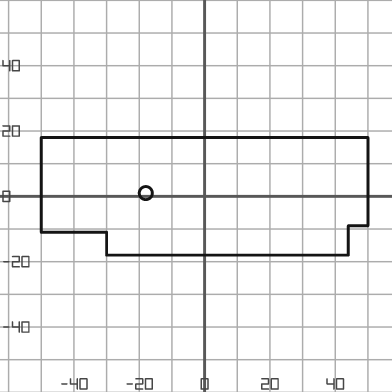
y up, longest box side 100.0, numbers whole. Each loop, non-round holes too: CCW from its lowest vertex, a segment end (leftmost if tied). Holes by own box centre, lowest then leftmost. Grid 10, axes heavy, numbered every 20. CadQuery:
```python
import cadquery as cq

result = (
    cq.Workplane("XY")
    .moveTo(-30.0, -18.0)
    .lineTo(44.0, -18.0)
    .lineTo(44.0, -9.0)
    .lineTo(50.0, -9.0)
    .lineTo(50.0, 18.0)
    .lineTo(-50.0, 18.0)
    .lineTo(-50.0, -11.0)
    .lineTo(-30.0, -11.0)
    .close()
    .moveTo(-18.0, 1.0)
    .circle(2.0)
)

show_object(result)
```